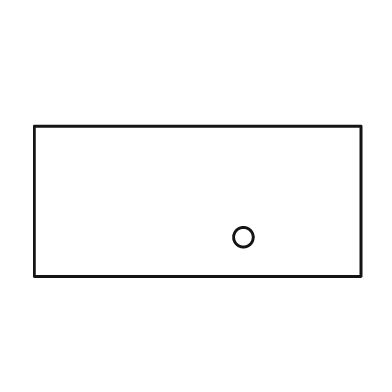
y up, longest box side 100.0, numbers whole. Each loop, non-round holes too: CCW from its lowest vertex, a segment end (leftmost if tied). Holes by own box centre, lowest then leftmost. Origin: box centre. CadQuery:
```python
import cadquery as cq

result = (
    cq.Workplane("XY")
    .moveTo(-50.0, -23.0)
    .lineTo(50.0, -23.0)
    .lineTo(50.0, 23.0)
    .lineTo(-50.0, 23.0)
    .close()
    .moveTo(14.0, -11.0)
    .circle(3.0)
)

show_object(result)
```